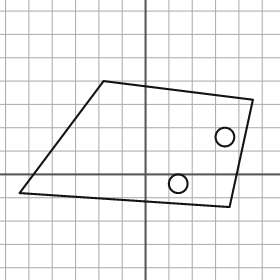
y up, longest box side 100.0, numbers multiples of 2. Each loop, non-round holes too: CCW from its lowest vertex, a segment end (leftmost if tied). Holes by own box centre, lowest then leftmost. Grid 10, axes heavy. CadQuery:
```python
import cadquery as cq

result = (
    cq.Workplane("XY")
    .moveTo(36.0, -14.0)
    .lineTo(46.0, 32.0)
    .lineTo(-18.0, 40.0)
    .lineTo(-54.0, -8.0)
    .close()
    .moveTo(14.0, -4.0)
    .circle(4.0)
    .moveTo(34.0, 16.0)
    .circle(4.0)
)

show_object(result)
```